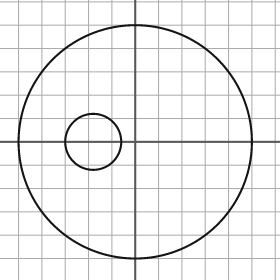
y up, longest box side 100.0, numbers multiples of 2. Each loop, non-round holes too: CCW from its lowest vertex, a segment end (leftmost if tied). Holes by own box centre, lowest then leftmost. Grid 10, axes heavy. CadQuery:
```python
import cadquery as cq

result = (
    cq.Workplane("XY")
    .moveTo(0.0, 0.0)
    .circle(50.0)
    .moveTo(-18.0, 0.0)
    .circle(12.0)
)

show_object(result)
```